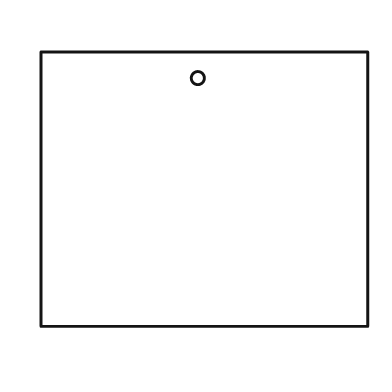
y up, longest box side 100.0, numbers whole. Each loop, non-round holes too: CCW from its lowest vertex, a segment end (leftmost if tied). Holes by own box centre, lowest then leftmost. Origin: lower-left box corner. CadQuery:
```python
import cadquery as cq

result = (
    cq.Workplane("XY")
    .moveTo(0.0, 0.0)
    .lineTo(100.0, 0.0)
    .lineTo(100.0, 84.0)
    .lineTo(0.0, 84.0)
    .close()
    .moveTo(48.0, 76.0)
    .circle(2.0)
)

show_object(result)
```